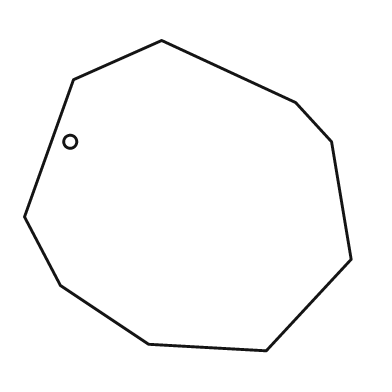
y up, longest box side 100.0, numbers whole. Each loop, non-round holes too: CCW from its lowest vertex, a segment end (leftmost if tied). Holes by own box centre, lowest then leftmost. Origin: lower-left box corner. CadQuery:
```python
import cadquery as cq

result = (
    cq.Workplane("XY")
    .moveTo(74.0, 0.0)
    .lineTo(100.0, 28.0)
    .lineTo(94.0, 64.0)
    .lineTo(83.0, 76.0)
    .lineTo(42.0, 95.0)
    .lineTo(15.0, 83.0)
    .lineTo(0.0, 41.0)
    .lineTo(11.0, 20.0)
    .lineTo(38.0, 2.0)
    .close()
    .moveTo(14.0, 64.0)
    .circle(2.0)
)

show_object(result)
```